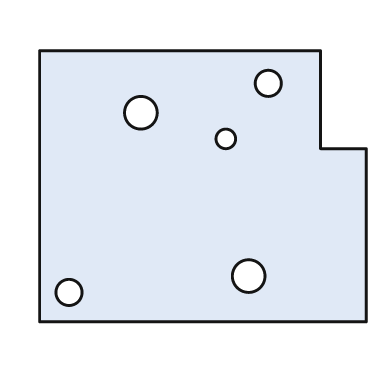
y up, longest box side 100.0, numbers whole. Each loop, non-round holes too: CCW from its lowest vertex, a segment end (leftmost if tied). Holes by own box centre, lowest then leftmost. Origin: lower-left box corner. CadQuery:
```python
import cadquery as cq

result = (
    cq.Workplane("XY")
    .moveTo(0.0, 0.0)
    .lineTo(100.0, 0.0)
    .lineTo(100.0, 53.0)
    .lineTo(86.0, 53.0)
    .lineTo(86.0, 83.0)
    .lineTo(0.0, 83.0)
    .close()
    .moveTo(9.0, 9.0)
    .circle(4.0)
    .moveTo(64.0, 14.0)
    .circle(5.0)
    .moveTo(57.0, 56.0)
    .circle(3.0)
    .moveTo(31.0, 64.0)
    .circle(5.0)
    .moveTo(70.0, 73.0)
    .circle(4.0)
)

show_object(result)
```